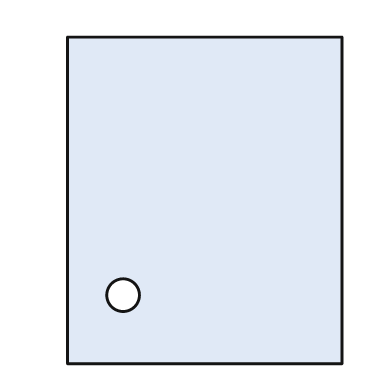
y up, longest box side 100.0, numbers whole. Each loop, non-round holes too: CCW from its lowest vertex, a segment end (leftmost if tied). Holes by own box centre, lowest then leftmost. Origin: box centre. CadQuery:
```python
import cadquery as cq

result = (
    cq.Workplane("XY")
    .moveTo(-42.0, -50.0)
    .lineTo(42.0, -50.0)
    .lineTo(42.0, 50.0)
    .lineTo(-42.0, 50.0)
    .close()
    .moveTo(-25.0, -29.0)
    .circle(5.0)
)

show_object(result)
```